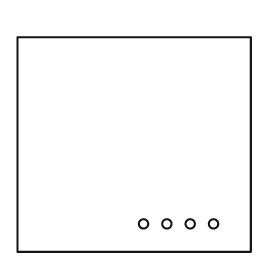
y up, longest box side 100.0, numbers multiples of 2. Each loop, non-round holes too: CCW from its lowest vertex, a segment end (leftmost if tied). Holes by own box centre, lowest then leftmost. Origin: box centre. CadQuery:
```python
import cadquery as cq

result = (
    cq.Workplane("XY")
    .moveTo(-50.0, -46.0)
    .lineTo(50.0, -46.0)
    .lineTo(50.0, 46.0)
    .lineTo(-50.0, 46.0)
    .close()
    .moveTo(4.0, -34.0)
    .circle(2.0)
    .moveTo(14.0, -34.0)
    .circle(2.0)
    .moveTo(24.0, -34.0)
    .circle(2.0)
    .moveTo(34.0, -34.0)
    .circle(2.0)
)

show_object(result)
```